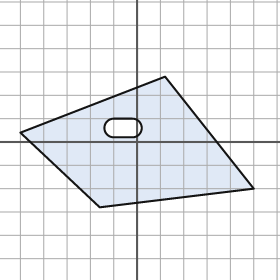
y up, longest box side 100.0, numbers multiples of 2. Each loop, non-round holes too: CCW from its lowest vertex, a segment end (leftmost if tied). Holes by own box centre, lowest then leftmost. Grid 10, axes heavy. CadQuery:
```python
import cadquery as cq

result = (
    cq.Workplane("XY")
    .moveTo(-16.0, -28.0)
    .lineTo(50.0, -20.0)
    .lineTo(12.0, 28.0)
    .lineTo(-50.0, 4.0)
    .close()
    .moveTo(-10.0, 2.0)
    .lineTo(-2.0, 2.0)
    .threePointArc((2.0, 6.0), (-2.0, 10.0))
    .lineTo(-10.0, 10.0)
    .threePointArc((-14.0, 6.0), (-10.0, 2.0))
    .close()
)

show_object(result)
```